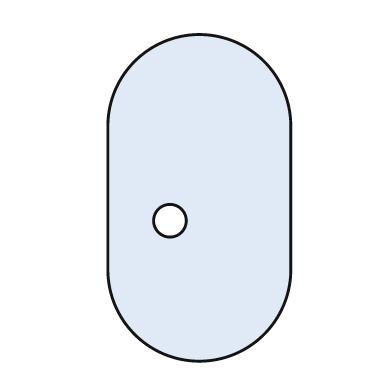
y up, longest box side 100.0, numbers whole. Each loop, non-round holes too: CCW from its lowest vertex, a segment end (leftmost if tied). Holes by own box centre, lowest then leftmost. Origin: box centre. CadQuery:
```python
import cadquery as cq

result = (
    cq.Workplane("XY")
    .moveTo(-28.0, -22.0)
    .threePointArc((0.0, -50.0), (28.0, -22.0))
    .lineTo(28.0, 22.0)
    .threePointArc((0.0, 50.0), (-28.0, 22.0))
    .close()
    .moveTo(-9.0, -7.0)
    .circle(5.0)
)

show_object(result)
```